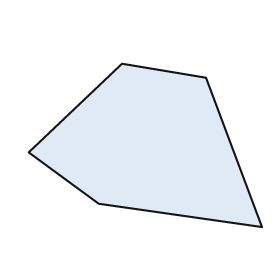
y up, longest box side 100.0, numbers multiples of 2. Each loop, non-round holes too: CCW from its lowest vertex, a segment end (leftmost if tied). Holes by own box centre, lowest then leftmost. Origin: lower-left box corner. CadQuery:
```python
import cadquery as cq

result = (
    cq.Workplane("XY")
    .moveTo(100.0, 0.0)
    .lineTo(76.0, 64.0)
    .lineTo(40.0, 70.0)
    .lineTo(0.0, 32.0)
    .lineTo(30.0, 10.0)
    .close()
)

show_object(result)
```